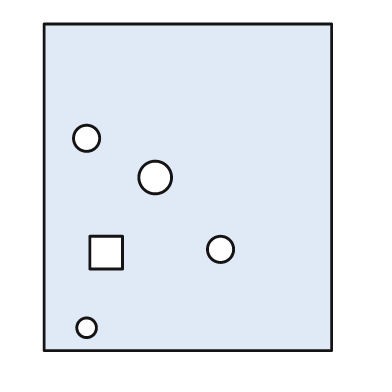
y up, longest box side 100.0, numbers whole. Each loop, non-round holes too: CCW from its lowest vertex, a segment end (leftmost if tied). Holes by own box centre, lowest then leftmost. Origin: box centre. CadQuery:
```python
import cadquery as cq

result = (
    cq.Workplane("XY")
    .moveTo(-44.0, -50.0)
    .lineTo(44.0, -50.0)
    .lineTo(44.0, 50.0)
    .lineTo(-44.0, 50.0)
    .close()
    .moveTo(-31.0, -43.0)
    .circle(3.0)
    .moveTo(-30.0, -25.0)
    .lineTo(-20.0, -25.0)
    .lineTo(-20.0, -15.0)
    .lineTo(-30.0, -15.0)
    .close()
    .moveTo(10.0, -19.0)
    .circle(4.0)
    .moveTo(-10.0, 3.0)
    .circle(5.0)
    .moveTo(-31.0, 15.0)
    .circle(4.0)
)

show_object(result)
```